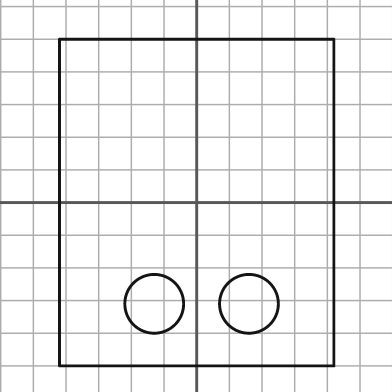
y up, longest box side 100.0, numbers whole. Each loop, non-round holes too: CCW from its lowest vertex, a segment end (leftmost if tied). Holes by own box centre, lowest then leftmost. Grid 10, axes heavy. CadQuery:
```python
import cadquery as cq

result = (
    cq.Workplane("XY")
    .moveTo(-42.0, -50.0)
    .lineTo(42.0, -50.0)
    .lineTo(42.0, 50.0)
    .lineTo(-42.0, 50.0)
    .close()
    .moveTo(-13.0, -31.0)
    .circle(9.0)
    .moveTo(16.0, -31.0)
    .circle(9.0)
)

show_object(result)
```